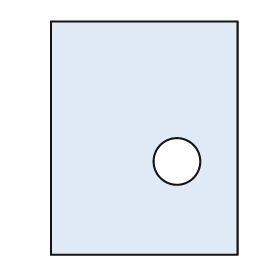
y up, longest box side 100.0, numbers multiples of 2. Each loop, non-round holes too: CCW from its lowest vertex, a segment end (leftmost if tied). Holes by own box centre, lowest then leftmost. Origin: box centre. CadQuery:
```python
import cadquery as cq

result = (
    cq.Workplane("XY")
    .moveTo(-40.0, -50.0)
    .lineTo(40.0, -50.0)
    .lineTo(40.0, 50.0)
    .lineTo(-40.0, 50.0)
    .close()
    .moveTo(14.0, -10.0)
    .circle(10.0)
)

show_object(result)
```